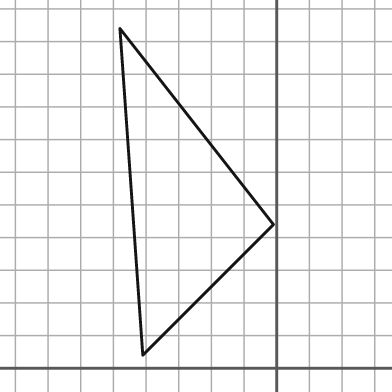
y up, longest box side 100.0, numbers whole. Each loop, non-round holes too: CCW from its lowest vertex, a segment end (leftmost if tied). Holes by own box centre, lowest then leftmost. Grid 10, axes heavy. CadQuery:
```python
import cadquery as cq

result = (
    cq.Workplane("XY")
    .moveTo(-41.0, 4.0)
    .lineTo(-1.0, 44.0)
    .lineTo(-48.0, 104.0)
    .close()
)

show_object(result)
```